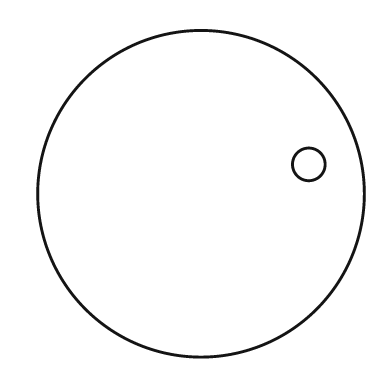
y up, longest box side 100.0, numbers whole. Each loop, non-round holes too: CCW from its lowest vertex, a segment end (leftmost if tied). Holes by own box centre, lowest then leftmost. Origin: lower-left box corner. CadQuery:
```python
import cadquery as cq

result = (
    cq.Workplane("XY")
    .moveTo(50.0, 50.0)
    .circle(50.0)
    .moveTo(83.0, 59.0)
    .circle(5.0)
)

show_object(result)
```